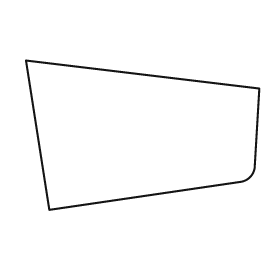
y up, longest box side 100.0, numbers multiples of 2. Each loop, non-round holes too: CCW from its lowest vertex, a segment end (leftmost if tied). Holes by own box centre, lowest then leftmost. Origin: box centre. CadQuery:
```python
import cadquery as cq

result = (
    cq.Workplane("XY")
    .moveTo(-40.0, -32.0)
    .lineTo(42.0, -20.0)
    .threePointArc((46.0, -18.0), (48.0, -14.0))
    .lineTo(50.0, 20.0)
    .lineTo(-50.0, 32.0)
    .close()
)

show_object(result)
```